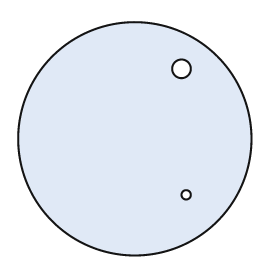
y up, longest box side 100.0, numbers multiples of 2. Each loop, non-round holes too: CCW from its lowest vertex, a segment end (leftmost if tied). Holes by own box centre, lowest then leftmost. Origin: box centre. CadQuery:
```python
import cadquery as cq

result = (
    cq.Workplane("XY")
    .moveTo(0.0, 0.0)
    .circle(50.0)
    .moveTo(22.0, -24.0)
    .circle(2.0)
    .moveTo(20.0, 30.0)
    .circle(4.0)
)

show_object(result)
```